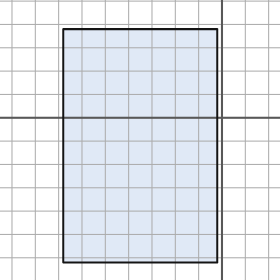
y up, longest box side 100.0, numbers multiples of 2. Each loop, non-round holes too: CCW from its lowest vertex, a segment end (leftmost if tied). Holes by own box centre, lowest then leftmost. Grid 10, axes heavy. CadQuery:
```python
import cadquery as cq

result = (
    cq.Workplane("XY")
    .moveTo(-68.0, -62.0)
    .lineTo(-2.0, -62.0)
    .lineTo(-2.0, 38.0)
    .lineTo(-68.0, 38.0)
    .close()
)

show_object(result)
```